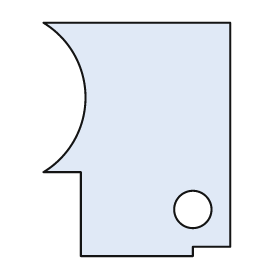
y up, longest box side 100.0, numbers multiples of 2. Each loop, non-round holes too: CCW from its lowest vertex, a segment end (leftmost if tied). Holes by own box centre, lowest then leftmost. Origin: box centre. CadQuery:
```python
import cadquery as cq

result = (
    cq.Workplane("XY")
    .moveTo(-24.0, -50.0)
    .lineTo(24.0, -50.0)
    .lineTo(24.0, -46.0)
    .lineTo(40.0, -46.0)
    .lineTo(40.0, 50.0)
    .lineTo(-40.0, 50.0)
    .threePointArc((-22.0, 18.0), (-40.0, -14.0))
    .lineTo(-24.0, -14.0)
    .close()
    .moveTo(24.0, -30.0)
    .circle(8.0)
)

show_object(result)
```